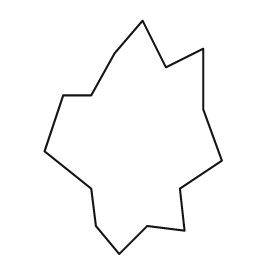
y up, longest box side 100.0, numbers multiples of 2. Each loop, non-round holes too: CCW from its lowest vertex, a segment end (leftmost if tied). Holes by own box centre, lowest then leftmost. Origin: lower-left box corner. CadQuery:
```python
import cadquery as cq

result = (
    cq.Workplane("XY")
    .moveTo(32.0, 0.0)
    .lineTo(44.0, 12.0)
    .lineTo(60.0, 10.0)
    .lineTo(58.0, 28.0)
    .lineTo(76.0, 40.0)
    .lineTo(68.0, 62.0)
    .lineTo(68.0, 88.0)
    .lineTo(52.0, 80.0)
    .lineTo(42.0, 100.0)
    .lineTo(30.0, 86.0)
    .lineTo(20.0, 68.0)
    .lineTo(8.0, 68.0)
    .lineTo(0.0, 44.0)
    .lineTo(20.0, 28.0)
    .lineTo(22.0, 12.0)
    .close()
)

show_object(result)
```